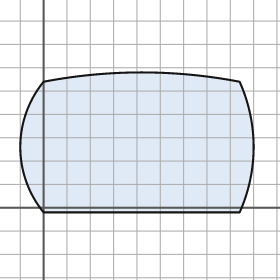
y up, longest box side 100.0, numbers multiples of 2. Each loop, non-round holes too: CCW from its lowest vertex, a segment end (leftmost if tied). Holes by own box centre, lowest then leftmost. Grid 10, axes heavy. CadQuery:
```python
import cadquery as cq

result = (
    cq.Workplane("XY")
    .moveTo(0.0, -2.0)
    .lineTo(84.0, -2.0)
    .threePointArc((90.0, 26.0), (84.0, 54.0))
    .threePointArc((42.0, 58.0), (0.0, 54.0))
    .threePointArc((-10.0, 26.0), (0.0, -2.0))
    .close()
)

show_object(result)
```